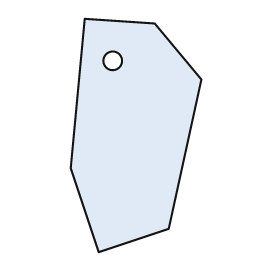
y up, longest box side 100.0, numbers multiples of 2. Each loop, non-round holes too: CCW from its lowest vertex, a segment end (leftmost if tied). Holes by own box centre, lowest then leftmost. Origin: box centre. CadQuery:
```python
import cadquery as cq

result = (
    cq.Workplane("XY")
    .moveTo(-16.0, -50.0)
    .lineTo(14.0, -40.0)
    .lineTo(28.0, 24.0)
    .lineTo(8.0, 48.0)
    .lineTo(-22.0, 50.0)
    .lineTo(-28.0, -14.0)
    .close()
    .moveTo(-10.0, 32.0)
    .circle(4.0)
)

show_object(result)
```